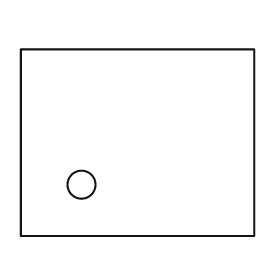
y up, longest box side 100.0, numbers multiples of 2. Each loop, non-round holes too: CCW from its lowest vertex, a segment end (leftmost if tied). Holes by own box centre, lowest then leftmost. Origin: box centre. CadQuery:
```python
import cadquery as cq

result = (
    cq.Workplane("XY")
    .moveTo(-50.0, -40.0)
    .lineTo(50.0, -40.0)
    .lineTo(50.0, 40.0)
    .lineTo(-50.0, 40.0)
    .close()
    .moveTo(-24.0, -18.0)
    .circle(6.0)
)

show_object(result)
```